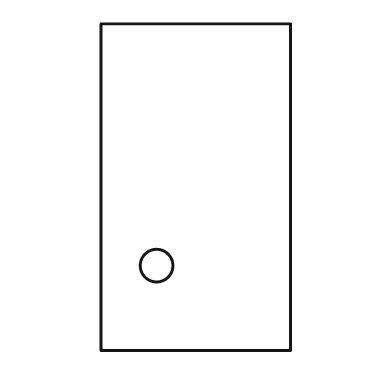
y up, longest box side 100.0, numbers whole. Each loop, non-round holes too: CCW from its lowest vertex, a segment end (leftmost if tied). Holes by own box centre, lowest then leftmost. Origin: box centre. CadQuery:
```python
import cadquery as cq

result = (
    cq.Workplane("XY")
    .moveTo(-29.0, -50.0)
    .lineTo(29.0, -50.0)
    .lineTo(29.0, 50.0)
    .lineTo(-29.0, 50.0)
    .close()
    .moveTo(-12.0, -24.0)
    .circle(5.0)
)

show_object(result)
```